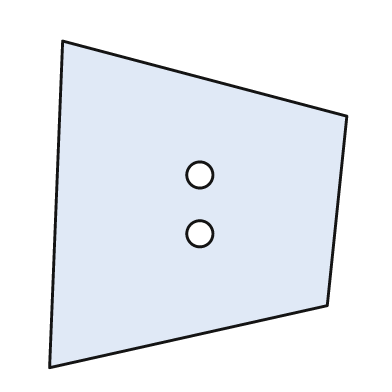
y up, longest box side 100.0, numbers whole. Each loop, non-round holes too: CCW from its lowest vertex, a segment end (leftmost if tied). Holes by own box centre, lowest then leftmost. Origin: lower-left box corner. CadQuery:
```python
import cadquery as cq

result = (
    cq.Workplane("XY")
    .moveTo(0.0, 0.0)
    .lineTo(85.0, 19.0)
    .lineTo(91.0, 77.0)
    .lineTo(4.0, 100.0)
    .close()
    .moveTo(46.0, 41.0)
    .circle(4.0)
    .moveTo(46.0, 59.0)
    .circle(4.0)
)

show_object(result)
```